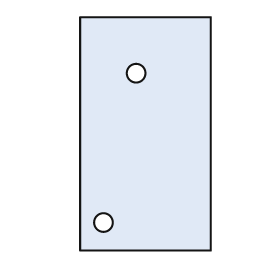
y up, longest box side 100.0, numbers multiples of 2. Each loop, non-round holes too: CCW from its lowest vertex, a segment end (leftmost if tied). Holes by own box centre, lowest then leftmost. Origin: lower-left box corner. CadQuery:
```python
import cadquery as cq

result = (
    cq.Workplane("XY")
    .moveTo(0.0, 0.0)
    .lineTo(56.0, 0.0)
    .lineTo(56.0, 100.0)
    .lineTo(0.0, 100.0)
    .close()
    .moveTo(10.0, 12.0)
    .circle(4.0)
    .moveTo(24.0, 76.0)
    .circle(4.0)
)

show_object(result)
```